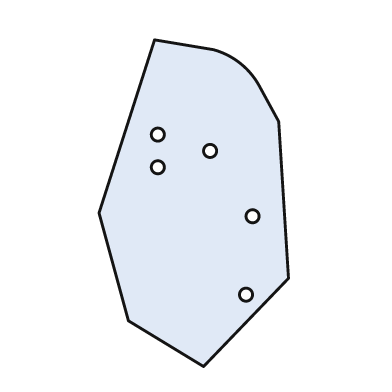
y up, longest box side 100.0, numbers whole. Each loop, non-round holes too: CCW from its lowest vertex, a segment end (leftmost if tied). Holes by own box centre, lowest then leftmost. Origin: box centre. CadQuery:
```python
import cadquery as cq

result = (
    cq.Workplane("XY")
    .moveTo(3.0, -50.0)
    .lineTo(29.0, -23.0)
    .lineTo(26.0, 25.0)
    .lineTo(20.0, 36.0)
    .threePointArc((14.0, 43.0), (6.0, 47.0))
    .lineTo(-12.0, 50.0)
    .lineTo(-29.0, -3.0)
    .lineTo(-20.0, -36.0)
    .close()
    .moveTo(16.0, -28.0)
    .circle(2.0)
    .moveTo(18.0, -4.0)
    .circle(2.0)
    .moveTo(-11.0, 11.0)
    .circle(2.0)
    .moveTo(5.0, 16.0)
    .circle(2.0)
    .moveTo(-11.0, 21.0)
    .circle(2.0)
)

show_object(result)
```